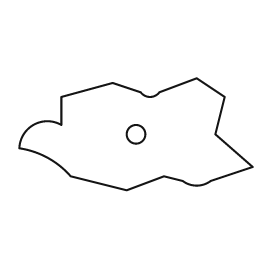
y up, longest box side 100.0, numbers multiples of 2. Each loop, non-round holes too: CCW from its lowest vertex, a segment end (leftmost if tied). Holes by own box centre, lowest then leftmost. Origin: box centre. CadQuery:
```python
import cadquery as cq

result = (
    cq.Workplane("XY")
    .moveTo(-4.0, -24.0)
    .lineTo(12.0, -18.0)
    .lineTo(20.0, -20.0)
    .threePointArc((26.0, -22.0), (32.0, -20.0))
    .lineTo(50.0, -14.0)
    .lineTo(34.0, 0.0)
    .lineTo(38.0, 16.0)
    .lineTo(26.0, 24.0)
    .lineTo(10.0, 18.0)
    .threePointArc((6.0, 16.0), (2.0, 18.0))
    .lineTo(-10.0, 22.0)
    .lineTo(-32.0, 16.0)
    .lineTo(-32.0, 4.0)
    .threePointArc((-44.0, 4.0), (-50.0, -6.0))
    .threePointArc((-38.0, -10.0), (-28.0, -18.0))
    .close()
    .moveTo(0.0, 0.0)
    .circle(4.0)
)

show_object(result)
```